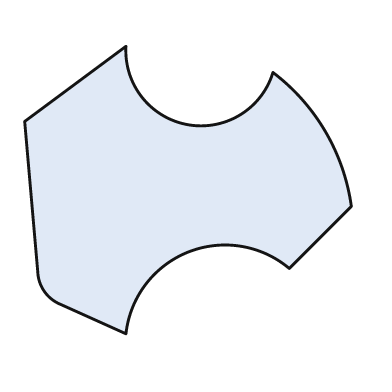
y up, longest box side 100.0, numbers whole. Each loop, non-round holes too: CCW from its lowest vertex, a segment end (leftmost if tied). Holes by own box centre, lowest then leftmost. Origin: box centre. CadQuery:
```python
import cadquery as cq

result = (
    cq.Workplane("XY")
    .moveTo(-19.0, -44.0)
    .threePointArc((0.0, -19.0), (31.0, -24.0))
    .lineTo(50.0, -5.0)
    .threePointArc((42.0, 18.0), (26.0, 36.0))
    .threePointArc((0.0, 20.0), (-19.0, 44.0))
    .lineTo(-50.0, 21.0)
    .lineTo(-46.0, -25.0)
    .threePointArc((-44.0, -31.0), (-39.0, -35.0))
    .close()
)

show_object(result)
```